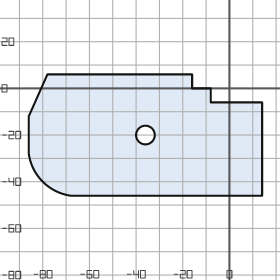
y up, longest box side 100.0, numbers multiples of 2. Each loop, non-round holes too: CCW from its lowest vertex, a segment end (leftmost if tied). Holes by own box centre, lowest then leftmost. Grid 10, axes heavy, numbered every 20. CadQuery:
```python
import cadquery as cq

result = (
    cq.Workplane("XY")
    .moveTo(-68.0, -46.0)
    .lineTo(14.0, -46.0)
    .lineTo(14.0, -6.0)
    .lineTo(-8.0, -6.0)
    .lineTo(-8.0, 0.0)
    .lineTo(-16.0, 0.0)
    .lineTo(-16.0, 6.0)
    .lineTo(-78.0, 6.0)
    .lineTo(-86.0, -12.0)
    .lineTo(-86.0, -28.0)
    .threePointArc((-80.0, -40.0), (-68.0, -46.0))
    .close()
    .moveTo(-36.0, -20.0)
    .circle(4.0)
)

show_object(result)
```